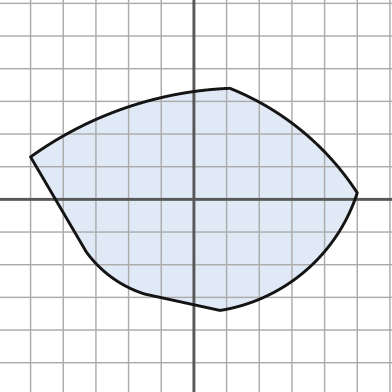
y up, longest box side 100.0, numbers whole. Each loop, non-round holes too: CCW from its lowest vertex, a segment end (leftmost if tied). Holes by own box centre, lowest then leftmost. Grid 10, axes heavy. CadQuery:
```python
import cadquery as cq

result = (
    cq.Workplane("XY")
    .moveTo(8.0, -34.0)
    .threePointArc((34.0, -22.0), (50.0, 2.0))
    .threePointArc((33.0, 21.0), (11.0, 34.0))
    .threePointArc((-21.0, 28.0), (-50.0, 13.0))
    .lineTo(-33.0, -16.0)
    .threePointArc((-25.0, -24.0), (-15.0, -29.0))
    .close()
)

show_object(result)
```